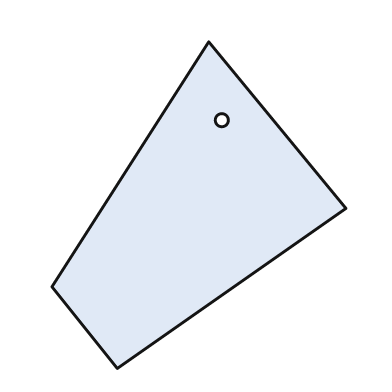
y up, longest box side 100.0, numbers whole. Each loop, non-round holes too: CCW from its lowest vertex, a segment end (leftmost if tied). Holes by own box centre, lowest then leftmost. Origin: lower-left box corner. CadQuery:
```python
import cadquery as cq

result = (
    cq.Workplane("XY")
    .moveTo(20.0, 0.0)
    .lineTo(90.0, 49.0)
    .lineTo(48.0, 100.0)
    .lineTo(0.0, 25.0)
    .close()
    .moveTo(52.0, 76.0)
    .circle(2.0)
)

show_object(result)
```